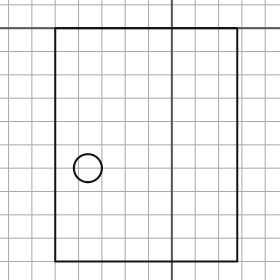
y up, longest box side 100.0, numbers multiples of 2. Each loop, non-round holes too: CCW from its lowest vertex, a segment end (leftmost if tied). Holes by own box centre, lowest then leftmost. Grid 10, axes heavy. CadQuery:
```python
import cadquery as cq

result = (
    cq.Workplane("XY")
    .moveTo(-50.0, -100.0)
    .lineTo(28.0, -100.0)
    .lineTo(28.0, 0.0)
    .lineTo(-50.0, 0.0)
    .close()
    .moveTo(-36.0, -60.0)
    .circle(6.0)
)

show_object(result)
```